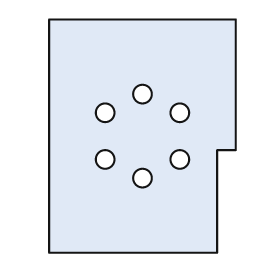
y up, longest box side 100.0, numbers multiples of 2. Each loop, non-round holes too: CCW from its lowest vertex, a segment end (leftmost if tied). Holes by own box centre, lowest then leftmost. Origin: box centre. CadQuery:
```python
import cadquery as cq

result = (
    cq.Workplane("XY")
    .moveTo(-40.0, -50.0)
    .lineTo(32.0, -50.0)
    .lineTo(32.0, -6.0)
    .lineTo(40.0, -6.0)
    .lineTo(40.0, 50.0)
    .lineTo(-40.0, 50.0)
    .close()
    .moveTo(0.0, -18.0)
    .circle(4.0)
    .moveTo(-16.0, -10.0)
    .circle(4.0)
    .moveTo(16.0, -10.0)
    .circle(4.0)
    .moveTo(-16.0, 10.0)
    .circle(4.0)
    .moveTo(16.0, 10.0)
    .circle(4.0)
    .moveTo(0.0, 18.0)
    .circle(4.0)
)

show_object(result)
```